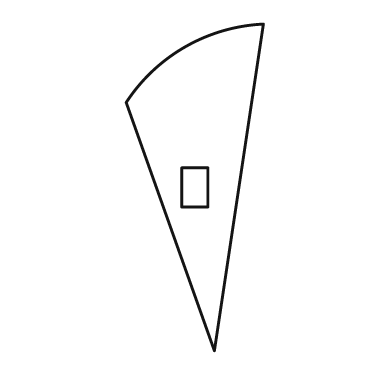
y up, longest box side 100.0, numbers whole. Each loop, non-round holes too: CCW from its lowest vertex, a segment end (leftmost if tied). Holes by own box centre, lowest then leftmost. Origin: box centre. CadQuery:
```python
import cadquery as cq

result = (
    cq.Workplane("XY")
    .moveTo(6.0, -50.0)
    .lineTo(21.0, 50.0)
    .threePointArc((-3.0, 43.0), (-21.0, 26.0))
    .close()
    .moveTo(-4.0, -6.0)
    .lineTo(4.0, -6.0)
    .lineTo(4.0, 6.0)
    .lineTo(-4.0, 6.0)
    .close()
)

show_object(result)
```